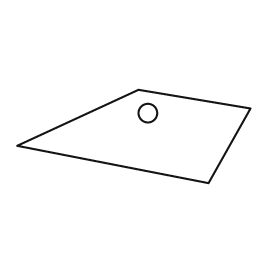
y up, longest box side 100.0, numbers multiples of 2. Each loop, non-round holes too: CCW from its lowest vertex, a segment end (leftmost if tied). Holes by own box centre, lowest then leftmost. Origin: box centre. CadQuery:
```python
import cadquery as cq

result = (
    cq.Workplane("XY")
    .moveTo(32.0, -20.0)
    .lineTo(50.0, 12.0)
    .lineTo(2.0, 20.0)
    .lineTo(-50.0, -4.0)
    .close()
    .moveTo(6.0, 10.0)
    .circle(4.0)
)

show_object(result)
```